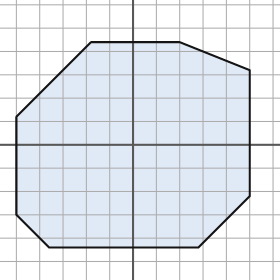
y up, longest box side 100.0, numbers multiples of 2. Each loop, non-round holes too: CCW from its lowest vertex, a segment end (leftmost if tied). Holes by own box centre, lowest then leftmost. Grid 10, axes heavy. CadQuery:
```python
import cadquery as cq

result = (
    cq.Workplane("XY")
    .moveTo(-36.0, -44.0)
    .lineTo(28.0, -44.0)
    .lineTo(50.0, -22.0)
    .lineTo(50.0, 32.0)
    .lineTo(20.0, 44.0)
    .lineTo(-18.0, 44.0)
    .lineTo(-50.0, 12.0)
    .lineTo(-50.0, -30.0)
    .close()
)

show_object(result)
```